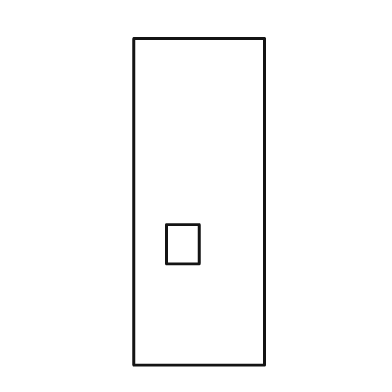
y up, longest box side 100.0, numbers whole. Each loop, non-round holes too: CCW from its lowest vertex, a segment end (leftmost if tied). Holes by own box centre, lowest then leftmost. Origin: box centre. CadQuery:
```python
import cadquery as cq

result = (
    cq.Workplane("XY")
    .moveTo(-20.0, -50.0)
    .lineTo(20.0, -50.0)
    .lineTo(20.0, 50.0)
    .lineTo(-20.0, 50.0)
    .close()
    .moveTo(-10.0, -19.0)
    .lineTo(0.0, -19.0)
    .lineTo(0.0, -7.0)
    .lineTo(-10.0, -7.0)
    .close()
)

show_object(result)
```